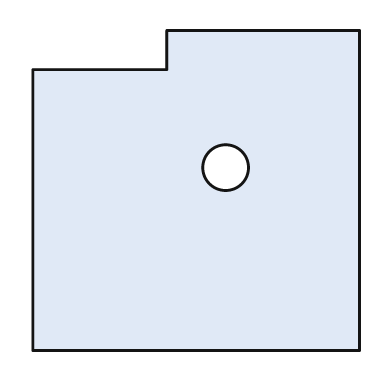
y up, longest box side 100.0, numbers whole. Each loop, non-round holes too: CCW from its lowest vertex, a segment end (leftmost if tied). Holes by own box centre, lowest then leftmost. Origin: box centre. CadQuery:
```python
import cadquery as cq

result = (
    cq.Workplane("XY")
    .moveTo(-50.0, -49.0)
    .lineTo(50.0, -49.0)
    .lineTo(50.0, 49.0)
    .lineTo(-9.0, 49.0)
    .lineTo(-9.0, 37.0)
    .lineTo(-50.0, 37.0)
    .close()
    .moveTo(9.0, 7.0)
    .circle(7.0)
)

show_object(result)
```